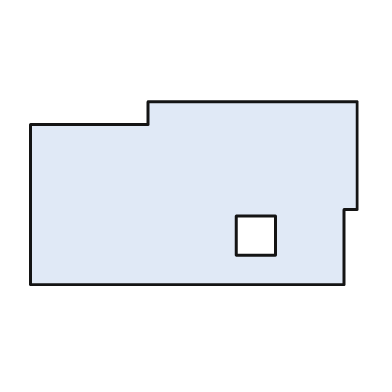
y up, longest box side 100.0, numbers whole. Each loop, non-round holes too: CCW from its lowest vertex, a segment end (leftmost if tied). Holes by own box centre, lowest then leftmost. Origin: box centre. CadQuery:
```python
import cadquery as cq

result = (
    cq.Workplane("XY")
    .moveTo(-50.0, -28.0)
    .lineTo(46.0, -28.0)
    .lineTo(46.0, -5.0)
    .lineTo(50.0, -5.0)
    .lineTo(50.0, 28.0)
    .lineTo(-14.0, 28.0)
    .lineTo(-14.0, 21.0)
    .lineTo(-50.0, 21.0)
    .close()
    .moveTo(13.0, -19.0)
    .lineTo(25.0, -19.0)
    .lineTo(25.0, -7.0)
    .lineTo(13.0, -7.0)
    .close()
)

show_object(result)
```